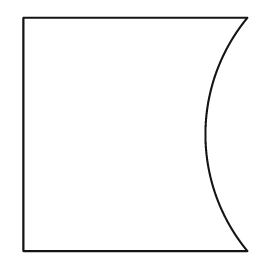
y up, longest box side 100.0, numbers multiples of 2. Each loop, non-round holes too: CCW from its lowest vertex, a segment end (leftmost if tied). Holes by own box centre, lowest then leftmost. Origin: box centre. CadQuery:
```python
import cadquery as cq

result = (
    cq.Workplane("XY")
    .moveTo(-48.0, -50.0)
    .lineTo(48.0, -50.0)
    .threePointArc((30.0, 0.0), (48.0, 50.0))
    .lineTo(-48.0, 50.0)
    .close()
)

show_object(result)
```